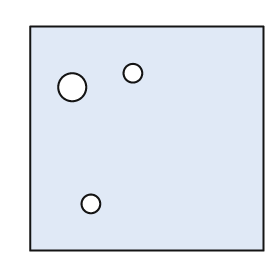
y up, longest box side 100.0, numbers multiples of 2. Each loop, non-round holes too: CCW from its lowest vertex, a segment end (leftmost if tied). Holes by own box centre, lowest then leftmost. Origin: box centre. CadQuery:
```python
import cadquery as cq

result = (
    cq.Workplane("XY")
    .moveTo(-50.0, -48.0)
    .lineTo(50.0, -48.0)
    .lineTo(50.0, 48.0)
    .lineTo(-50.0, 48.0)
    .close()
    .moveTo(-24.0, -28.0)
    .circle(4.0)
    .moveTo(-32.0, 22.0)
    .circle(6.0)
    .moveTo(-6.0, 28.0)
    .circle(4.0)
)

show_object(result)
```